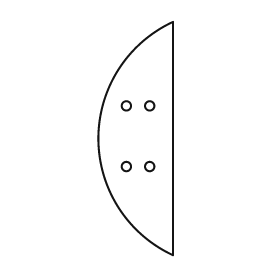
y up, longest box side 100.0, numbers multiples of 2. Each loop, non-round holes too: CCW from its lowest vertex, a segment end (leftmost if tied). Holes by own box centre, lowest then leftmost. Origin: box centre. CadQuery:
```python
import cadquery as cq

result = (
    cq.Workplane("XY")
    .moveTo(16.0, -50.0)
    .lineTo(16.0, 50.0)
    .threePointArc((-16.0, 0.0), (16.0, -50.0))
    .close()
    .moveTo(-4.0, -12.0)
    .circle(2.0)
    .moveTo(6.0, -12.0)
    .circle(2.0)
    .moveTo(-4.0, 14.0)
    .circle(2.0)
    .moveTo(6.0, 14.0)
    .circle(2.0)
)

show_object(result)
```